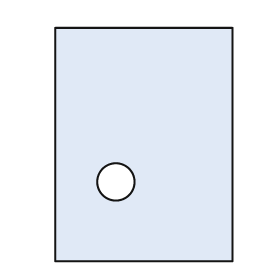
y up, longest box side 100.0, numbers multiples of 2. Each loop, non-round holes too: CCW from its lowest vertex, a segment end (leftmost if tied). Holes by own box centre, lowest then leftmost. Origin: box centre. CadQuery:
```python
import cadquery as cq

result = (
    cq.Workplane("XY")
    .moveTo(-38.0, -50.0)
    .lineTo(38.0, -50.0)
    .lineTo(38.0, 50.0)
    .lineTo(-38.0, 50.0)
    .close()
    .moveTo(-12.0, -16.0)
    .circle(8.0)
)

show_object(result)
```